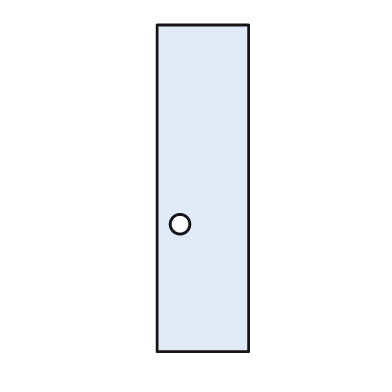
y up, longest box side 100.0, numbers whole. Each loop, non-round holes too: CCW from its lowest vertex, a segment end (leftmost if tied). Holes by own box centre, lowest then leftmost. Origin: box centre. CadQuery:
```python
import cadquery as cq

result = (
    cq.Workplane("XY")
    .moveTo(-14.0, -50.0)
    .lineTo(14.0, -50.0)
    .lineTo(14.0, 50.0)
    .lineTo(-14.0, 50.0)
    .close()
    .moveTo(-7.0, -11.0)
    .circle(3.0)
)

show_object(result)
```